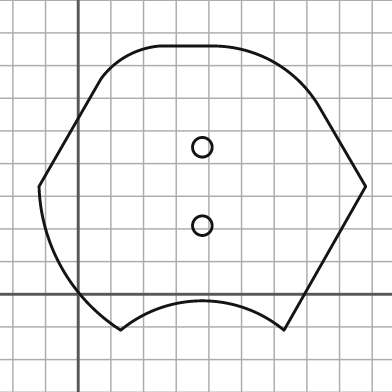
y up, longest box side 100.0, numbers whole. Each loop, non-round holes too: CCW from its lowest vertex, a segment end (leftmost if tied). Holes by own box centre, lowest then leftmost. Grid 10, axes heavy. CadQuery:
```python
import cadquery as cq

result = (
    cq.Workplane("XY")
    .moveTo(13.0, -11.0)
    .threePointArc((38.0, -2.0), (63.0, -11.0))
    .lineTo(88.0, 33.0)
    .lineTo(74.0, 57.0)
    .threePointArc((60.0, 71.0), (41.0, 76.0))
    .lineTo(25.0, 76.0)
    .threePointArc((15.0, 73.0), (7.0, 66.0))
    .lineTo(-12.0, 33.0)
    .threePointArc((-5.0, 8.0), (13.0, -11.0))
    .close()
    .moveTo(38.0, 21.0)
    .circle(3.0)
    .moveTo(38.0, 45.0)
    .circle(3.0)
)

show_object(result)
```